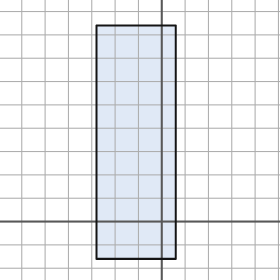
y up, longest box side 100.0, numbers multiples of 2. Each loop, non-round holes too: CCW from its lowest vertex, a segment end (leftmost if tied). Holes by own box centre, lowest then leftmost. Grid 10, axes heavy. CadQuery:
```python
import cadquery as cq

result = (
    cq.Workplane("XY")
    .moveTo(-28.0, -16.0)
    .lineTo(6.0, -16.0)
    .lineTo(6.0, 84.0)
    .lineTo(-28.0, 84.0)
    .close()
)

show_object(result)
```